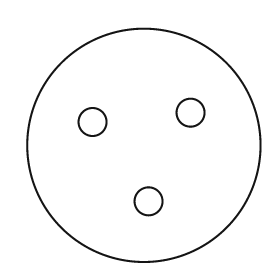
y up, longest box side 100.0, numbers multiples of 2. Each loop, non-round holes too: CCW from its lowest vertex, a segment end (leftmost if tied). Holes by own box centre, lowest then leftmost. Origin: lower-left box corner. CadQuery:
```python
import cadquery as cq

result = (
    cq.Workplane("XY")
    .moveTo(50.0, 50.0)
    .circle(50.0)
    .moveTo(52.0, 26.0)
    .circle(6.0)
    .moveTo(28.0, 60.0)
    .circle(6.0)
    .moveTo(70.0, 64.0)
    .circle(6.0)
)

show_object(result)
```